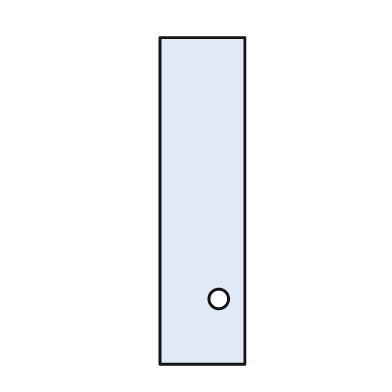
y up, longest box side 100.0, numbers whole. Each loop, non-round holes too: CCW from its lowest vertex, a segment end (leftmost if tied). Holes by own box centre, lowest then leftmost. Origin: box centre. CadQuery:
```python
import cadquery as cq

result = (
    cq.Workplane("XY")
    .moveTo(-13.0, -50.0)
    .lineTo(13.0, -50.0)
    .lineTo(13.0, 50.0)
    .lineTo(-13.0, 50.0)
    .close()
    .moveTo(5.0, -30.0)
    .circle(3.0)
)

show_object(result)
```